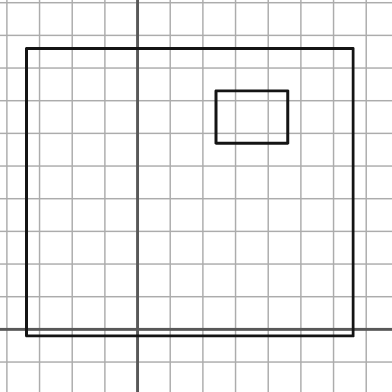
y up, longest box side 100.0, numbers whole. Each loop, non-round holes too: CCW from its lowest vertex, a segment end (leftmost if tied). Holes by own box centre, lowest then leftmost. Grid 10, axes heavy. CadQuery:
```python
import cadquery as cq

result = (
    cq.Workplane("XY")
    .moveTo(-34.0, -2.0)
    .lineTo(66.0, -2.0)
    .lineTo(66.0, 86.0)
    .lineTo(-34.0, 86.0)
    .close()
    .moveTo(24.0, 57.0)
    .lineTo(46.0, 57.0)
    .lineTo(46.0, 73.0)
    .lineTo(24.0, 73.0)
    .close()
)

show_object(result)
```